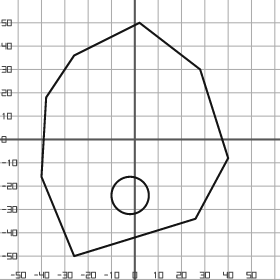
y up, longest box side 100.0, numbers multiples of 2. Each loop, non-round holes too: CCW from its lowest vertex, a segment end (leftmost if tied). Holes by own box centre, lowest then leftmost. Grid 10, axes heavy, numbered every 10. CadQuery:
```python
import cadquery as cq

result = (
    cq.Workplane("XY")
    .moveTo(-26.0, -50.0)
    .lineTo(26.0, -34.0)
    .lineTo(40.0, -8.0)
    .lineTo(28.0, 30.0)
    .lineTo(2.0, 50.0)
    .lineTo(-26.0, 36.0)
    .lineTo(-38.0, 18.0)
    .lineTo(-40.0, -16.0)
    .close()
    .moveTo(-2.0, -24.0)
    .circle(8.0)
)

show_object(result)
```